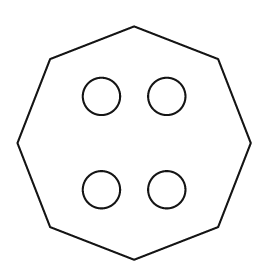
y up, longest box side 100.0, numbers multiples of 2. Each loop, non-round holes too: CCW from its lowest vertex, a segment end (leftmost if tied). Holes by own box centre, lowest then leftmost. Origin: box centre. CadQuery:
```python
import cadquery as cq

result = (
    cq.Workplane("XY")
    .moveTo(0.0, -50.0)
    .lineTo(36.0, -36.0)
    .lineTo(50.0, 0.0)
    .lineTo(36.0, 36.0)
    .lineTo(0.0, 50.0)
    .lineTo(-36.0, 36.0)
    .lineTo(-50.0, 0.0)
    .lineTo(-36.0, -36.0)
    .close()
    .moveTo(-14.0, -20.0)
    .circle(8.0)
    .moveTo(14.0, -20.0)
    .circle(8.0)
    .moveTo(-14.0, 20.0)
    .circle(8.0)
    .moveTo(14.0, 20.0)
    .circle(8.0)
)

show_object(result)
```